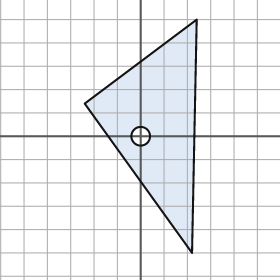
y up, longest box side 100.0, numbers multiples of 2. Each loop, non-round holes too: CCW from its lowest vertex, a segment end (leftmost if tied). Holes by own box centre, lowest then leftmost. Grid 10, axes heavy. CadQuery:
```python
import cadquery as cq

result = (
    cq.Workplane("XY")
    .moveTo(22.0, -50.0)
    .lineTo(24.0, 50.0)
    .lineTo(-24.0, 14.0)
    .close()
    .moveTo(0.0, 0.0)
    .circle(4.0)
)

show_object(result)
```